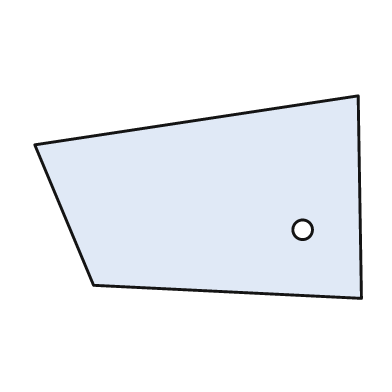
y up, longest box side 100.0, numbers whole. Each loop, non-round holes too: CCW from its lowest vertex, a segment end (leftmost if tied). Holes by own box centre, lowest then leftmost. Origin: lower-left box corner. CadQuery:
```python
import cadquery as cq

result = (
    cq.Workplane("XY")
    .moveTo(100.0, 0.0)
    .lineTo(99.0, 62.0)
    .lineTo(0.0, 47.0)
    .lineTo(18.0, 4.0)
    .close()
    .moveTo(82.0, 21.0)
    .circle(3.0)
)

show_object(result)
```